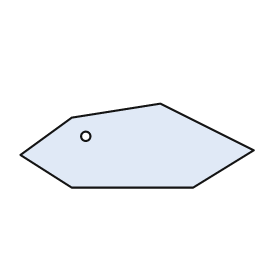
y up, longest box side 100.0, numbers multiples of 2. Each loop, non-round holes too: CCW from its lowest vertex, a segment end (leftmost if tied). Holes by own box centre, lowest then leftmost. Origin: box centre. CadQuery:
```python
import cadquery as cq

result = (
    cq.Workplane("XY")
    .moveTo(-28.0, -18.0)
    .lineTo(24.0, -18.0)
    .lineTo(50.0, -2.0)
    .lineTo(10.0, 18.0)
    .lineTo(-28.0, 12.0)
    .lineTo(-50.0, -4.0)
    .close()
    .moveTo(-22.0, 4.0)
    .circle(2.0)
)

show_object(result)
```